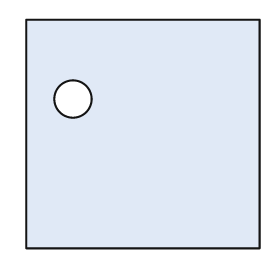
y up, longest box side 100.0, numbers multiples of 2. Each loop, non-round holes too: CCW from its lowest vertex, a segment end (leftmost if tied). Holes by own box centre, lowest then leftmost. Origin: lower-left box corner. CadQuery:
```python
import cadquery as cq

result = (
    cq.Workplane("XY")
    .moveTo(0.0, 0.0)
    .lineTo(100.0, 0.0)
    .lineTo(100.0, 98.0)
    .lineTo(0.0, 98.0)
    .close()
    .moveTo(20.0, 64.0)
    .circle(8.0)
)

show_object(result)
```